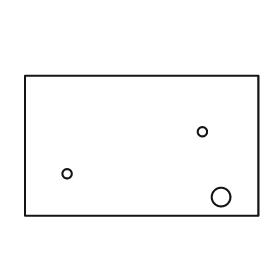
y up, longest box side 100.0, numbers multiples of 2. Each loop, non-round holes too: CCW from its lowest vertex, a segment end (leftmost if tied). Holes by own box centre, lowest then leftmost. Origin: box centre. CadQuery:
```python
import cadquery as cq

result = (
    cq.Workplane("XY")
    .moveTo(-50.0, -30.0)
    .lineTo(50.0, -30.0)
    .lineTo(50.0, 30.0)
    .lineTo(-50.0, 30.0)
    .close()
    .moveTo(34.0, -22.0)
    .circle(4.0)
    .moveTo(-32.0, -12.0)
    .circle(2.0)
    .moveTo(26.0, 6.0)
    .circle(2.0)
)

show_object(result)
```